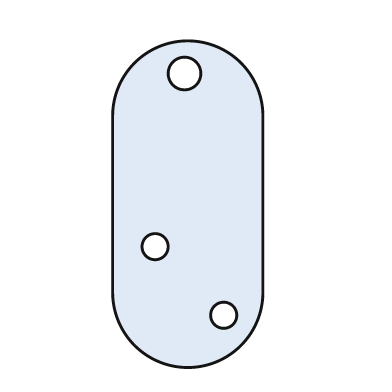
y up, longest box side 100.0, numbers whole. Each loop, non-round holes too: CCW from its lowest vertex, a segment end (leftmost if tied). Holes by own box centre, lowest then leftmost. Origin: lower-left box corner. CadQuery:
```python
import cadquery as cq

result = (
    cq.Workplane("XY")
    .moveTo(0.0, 23.0)
    .threePointArc((23.0, 0.0), (46.0, 23.0))
    .lineTo(46.0, 77.0)
    .threePointArc((23.0, 100.0), (0.0, 77.0))
    .close()
    .moveTo(34.0, 16.0)
    .circle(4.0)
    .moveTo(13.0, 37.0)
    .circle(4.0)
    .moveTo(22.0, 90.0)
    .circle(5.0)
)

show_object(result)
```